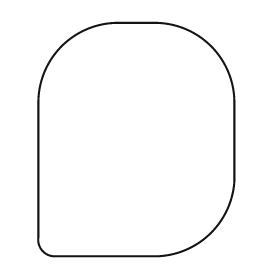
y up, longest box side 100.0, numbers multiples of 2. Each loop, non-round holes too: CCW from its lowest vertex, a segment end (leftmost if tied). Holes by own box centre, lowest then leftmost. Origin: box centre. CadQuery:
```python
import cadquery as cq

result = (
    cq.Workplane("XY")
    .moveTo(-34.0, -50.0)
    .lineTo(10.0, -50.0)
    .threePointArc((32.0, -40.0), (42.0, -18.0))
    .lineTo(42.0, 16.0)
    .threePointArc((32.0, 40.0), (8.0, 50.0))
    .lineTo(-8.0, 50.0)
    .threePointArc((-32.0, 40.0), (-42.0, 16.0))
    .lineTo(-42.0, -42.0)
    .threePointArc((-40.0, -48.0), (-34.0, -50.0))
    .close()
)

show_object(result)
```